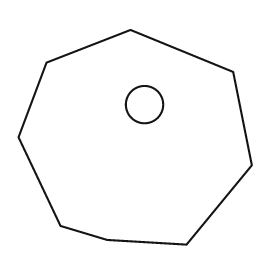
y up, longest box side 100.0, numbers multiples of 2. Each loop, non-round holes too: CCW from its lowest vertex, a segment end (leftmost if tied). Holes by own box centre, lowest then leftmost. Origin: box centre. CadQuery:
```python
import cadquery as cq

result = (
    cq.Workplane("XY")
    .moveTo(22.0, -46.0)
    .lineTo(50.0, -12.0)
    .lineTo(42.0, 28.0)
    .lineTo(-2.0, 46.0)
    .lineTo(-38.0, 32.0)
    .lineTo(-50.0, 0.0)
    .lineTo(-32.0, -38.0)
    .lineTo(-12.0, -44.0)
    .close()
    .moveTo(4.0, 14.0)
    .circle(8.0)
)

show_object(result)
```